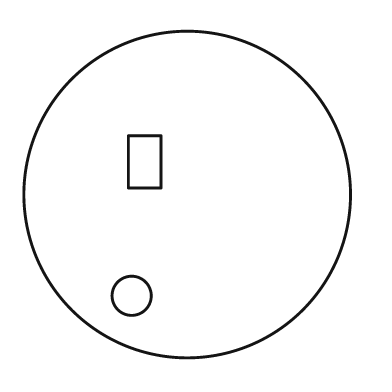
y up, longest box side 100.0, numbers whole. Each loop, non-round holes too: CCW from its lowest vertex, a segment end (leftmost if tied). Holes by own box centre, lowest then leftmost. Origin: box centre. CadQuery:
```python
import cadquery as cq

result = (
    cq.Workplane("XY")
    .moveTo(0.0, 0.0)
    .circle(50.0)
    .moveTo(-17.0, -31.0)
    .circle(6.0)
    .moveTo(-18.0, 2.0)
    .lineTo(-8.0, 2.0)
    .lineTo(-8.0, 18.0)
    .lineTo(-18.0, 18.0)
    .close()
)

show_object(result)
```